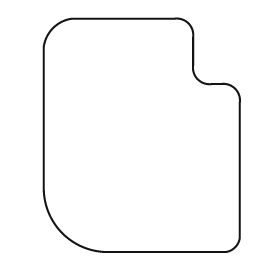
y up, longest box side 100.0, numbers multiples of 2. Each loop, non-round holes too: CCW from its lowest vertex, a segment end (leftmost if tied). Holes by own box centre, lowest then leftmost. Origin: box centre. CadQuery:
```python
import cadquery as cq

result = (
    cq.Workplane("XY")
    .moveTo(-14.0, -50.0)
    .lineTo(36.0, -50.0)
    .threePointArc((40.0, -48.0), (42.0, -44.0))
    .lineTo(42.0, 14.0)
    .threePointArc((40.0, 20.0), (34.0, 22.0))
    .lineTo(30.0, 22.0)
    .threePointArc((24.0, 24.0), (22.0, 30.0))
    .lineTo(22.0, 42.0)
    .threePointArc((20.0, 48.0), (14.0, 50.0))
    .lineTo(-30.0, 50.0)
    .threePointArc((-38.0, 46.0), (-42.0, 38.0))
    .lineTo(-42.0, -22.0)
    .threePointArc((-34.0, -42.0), (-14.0, -50.0))
    .close()
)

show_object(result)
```